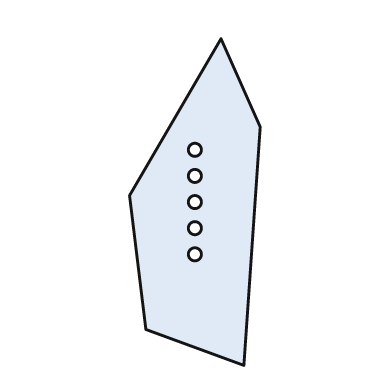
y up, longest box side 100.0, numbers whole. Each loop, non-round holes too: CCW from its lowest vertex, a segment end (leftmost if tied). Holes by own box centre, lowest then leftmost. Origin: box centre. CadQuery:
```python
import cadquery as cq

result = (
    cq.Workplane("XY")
    .moveTo(15.0, -50.0)
    .lineTo(20.0, 23.0)
    .lineTo(8.0, 50.0)
    .lineTo(-20.0, 2.0)
    .lineTo(-15.0, -39.0)
    .close()
    .moveTo(0.0, -16.0)
    .circle(2.0)
    .moveTo(0.0, -8.0)
    .circle(2.0)
    .moveTo(0.0, 0.0)
    .circle(2.0)
    .moveTo(0.0, 8.0)
    .circle(2.0)
    .moveTo(0.0, 16.0)
    .circle(2.0)
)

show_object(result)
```